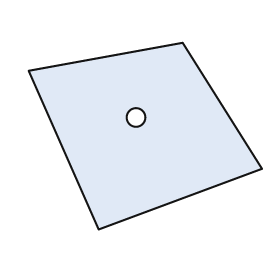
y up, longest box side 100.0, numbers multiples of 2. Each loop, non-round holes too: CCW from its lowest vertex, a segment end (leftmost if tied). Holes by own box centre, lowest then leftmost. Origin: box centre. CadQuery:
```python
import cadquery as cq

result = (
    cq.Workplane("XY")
    .moveTo(-20.0, -40.0)
    .lineTo(50.0, -14.0)
    .lineTo(16.0, 40.0)
    .lineTo(-50.0, 28.0)
    .close()
    .moveTo(-4.0, 8.0)
    .circle(4.0)
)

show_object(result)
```